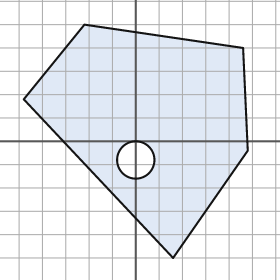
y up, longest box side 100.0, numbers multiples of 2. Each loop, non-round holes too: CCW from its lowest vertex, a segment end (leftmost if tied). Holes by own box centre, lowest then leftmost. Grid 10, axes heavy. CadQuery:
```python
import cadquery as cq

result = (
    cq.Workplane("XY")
    .moveTo(16.0, -50.0)
    .lineTo(48.0, -4.0)
    .lineTo(46.0, 40.0)
    .lineTo(-22.0, 50.0)
    .lineTo(-48.0, 18.0)
    .close()
    .moveTo(0.0, -8.0)
    .circle(8.0)
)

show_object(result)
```